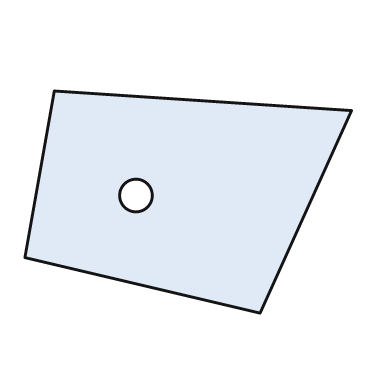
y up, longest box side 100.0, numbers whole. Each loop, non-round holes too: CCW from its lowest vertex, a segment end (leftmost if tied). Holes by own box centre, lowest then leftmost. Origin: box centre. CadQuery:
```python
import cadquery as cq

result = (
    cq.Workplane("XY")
    .moveTo(22.0, -34.0)
    .lineTo(50.0, 28.0)
    .lineTo(-41.0, 34.0)
    .lineTo(-50.0, -17.0)
    .close()
    .moveTo(-16.0, 2.0)
    .circle(5.0)
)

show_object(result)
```